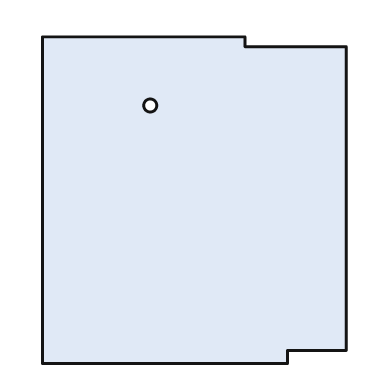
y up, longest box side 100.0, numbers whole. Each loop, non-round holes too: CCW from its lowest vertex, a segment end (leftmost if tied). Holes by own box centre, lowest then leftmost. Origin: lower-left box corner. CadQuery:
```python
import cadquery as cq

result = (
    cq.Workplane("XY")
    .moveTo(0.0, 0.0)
    .lineTo(75.0, 0.0)
    .lineTo(75.0, 4.0)
    .lineTo(93.0, 4.0)
    .lineTo(93.0, 97.0)
    .lineTo(62.0, 97.0)
    .lineTo(62.0, 100.0)
    .lineTo(0.0, 100.0)
    .close()
    .moveTo(33.0, 79.0)
    .circle(2.0)
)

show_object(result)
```